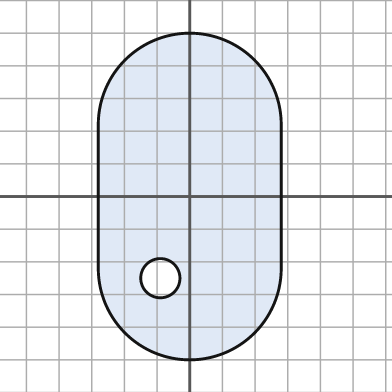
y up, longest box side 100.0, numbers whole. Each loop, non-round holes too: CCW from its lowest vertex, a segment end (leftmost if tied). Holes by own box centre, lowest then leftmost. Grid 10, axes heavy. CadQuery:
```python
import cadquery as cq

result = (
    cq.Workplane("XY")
    .moveTo(-28.0, -22.0)
    .threePointArc((0.0, -50.0), (28.0, -22.0))
    .lineTo(28.0, 22.0)
    .threePointArc((0.0, 50.0), (-28.0, 22.0))
    .close()
    .moveTo(-9.0, -25.0)
    .circle(6.0)
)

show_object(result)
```